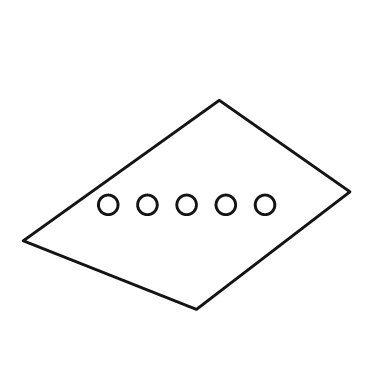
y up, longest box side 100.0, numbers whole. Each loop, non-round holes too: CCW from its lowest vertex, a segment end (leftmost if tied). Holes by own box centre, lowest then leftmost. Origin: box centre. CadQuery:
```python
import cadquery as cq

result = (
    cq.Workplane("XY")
    .moveTo(3.0, -32.0)
    .lineTo(50.0, 4.0)
    .lineTo(10.0, 32.0)
    .lineTo(-50.0, -11.0)
    .close()
    .moveTo(-24.0, 0.0)
    .circle(3.0)
    .moveTo(-12.0, 0.0)
    .circle(3.0)
    .moveTo(0.0, 0.0)
    .circle(3.0)
    .moveTo(12.0, 0.0)
    .circle(3.0)
    .moveTo(24.0, 0.0)
    .circle(3.0)
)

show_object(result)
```